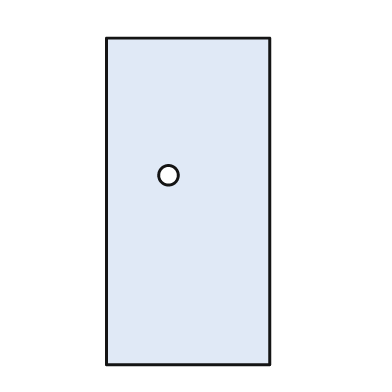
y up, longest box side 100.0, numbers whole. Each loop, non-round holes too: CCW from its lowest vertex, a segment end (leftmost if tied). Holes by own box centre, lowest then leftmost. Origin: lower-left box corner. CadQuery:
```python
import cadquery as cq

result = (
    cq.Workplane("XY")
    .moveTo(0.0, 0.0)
    .lineTo(50.0, 0.0)
    .lineTo(50.0, 100.0)
    .lineTo(0.0, 100.0)
    .close()
    .moveTo(19.0, 58.0)
    .circle(3.0)
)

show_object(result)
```